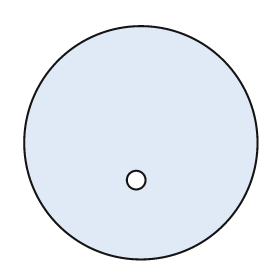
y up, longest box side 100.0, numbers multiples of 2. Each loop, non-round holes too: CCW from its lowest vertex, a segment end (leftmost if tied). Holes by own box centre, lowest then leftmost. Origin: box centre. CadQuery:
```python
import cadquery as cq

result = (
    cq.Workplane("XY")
    .moveTo(0.0, 0.0)
    .circle(50.0)
    .moveTo(-2.0, -16.0)
    .circle(4.0)
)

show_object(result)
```